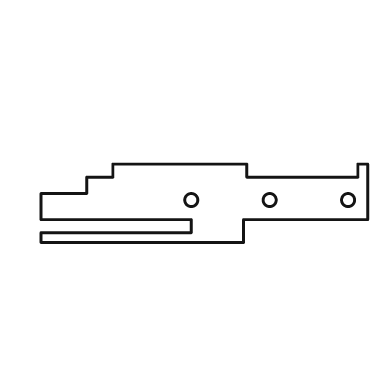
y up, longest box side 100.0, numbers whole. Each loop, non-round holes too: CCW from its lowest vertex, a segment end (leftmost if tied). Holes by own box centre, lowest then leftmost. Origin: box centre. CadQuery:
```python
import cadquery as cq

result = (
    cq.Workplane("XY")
    .moveTo(-50.0, -12.0)
    .lineTo(12.0, -12.0)
    .lineTo(12.0, -5.0)
    .lineTo(50.0, -5.0)
    .lineTo(50.0, 12.0)
    .lineTo(47.0, 12.0)
    .lineTo(47.0, 8.0)
    .lineTo(13.0, 8.0)
    .lineTo(13.0, 12.0)
    .lineTo(-28.0, 12.0)
    .lineTo(-28.0, 8.0)
    .lineTo(-36.0, 8.0)
    .lineTo(-36.0, 3.0)
    .lineTo(-50.0, 3.0)
    .lineTo(-50.0, -5.0)
    .lineTo(-4.0, -5.0)
    .lineTo(-4.0, -9.0)
    .lineTo(-50.0, -9.0)
    .close()
    .moveTo(-4.0, 1.0)
    .circle(2.0)
    .moveTo(20.0, 1.0)
    .circle(2.0)
    .moveTo(44.0, 1.0)
    .circle(2.0)
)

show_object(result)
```